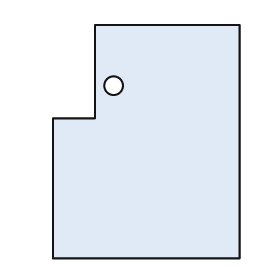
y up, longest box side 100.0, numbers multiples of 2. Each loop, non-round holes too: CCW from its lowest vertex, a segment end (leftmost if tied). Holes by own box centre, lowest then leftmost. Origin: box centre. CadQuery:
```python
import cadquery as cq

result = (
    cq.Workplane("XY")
    .moveTo(-40.0, -50.0)
    .lineTo(40.0, -50.0)
    .lineTo(40.0, 50.0)
    .lineTo(-22.0, 50.0)
    .lineTo(-22.0, 10.0)
    .lineTo(-40.0, 10.0)
    .close()
    .moveTo(-14.0, 24.0)
    .circle(4.0)
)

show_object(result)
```